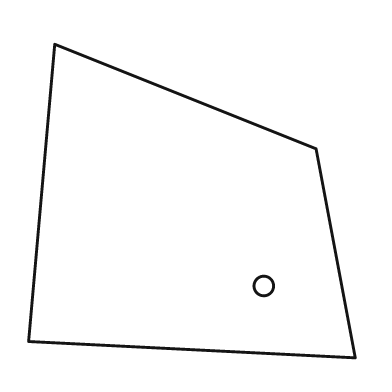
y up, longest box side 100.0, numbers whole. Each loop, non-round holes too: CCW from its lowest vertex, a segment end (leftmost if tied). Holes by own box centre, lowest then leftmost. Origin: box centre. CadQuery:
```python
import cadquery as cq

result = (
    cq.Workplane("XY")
    .moveTo(50.0, -48.0)
    .lineTo(38.0, 16.0)
    .lineTo(-42.0, 48.0)
    .lineTo(-50.0, -43.0)
    .close()
    .moveTo(22.0, -26.0)
    .circle(3.0)
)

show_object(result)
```